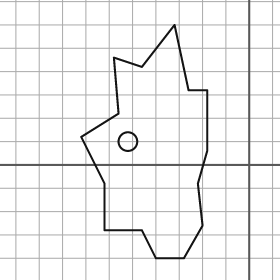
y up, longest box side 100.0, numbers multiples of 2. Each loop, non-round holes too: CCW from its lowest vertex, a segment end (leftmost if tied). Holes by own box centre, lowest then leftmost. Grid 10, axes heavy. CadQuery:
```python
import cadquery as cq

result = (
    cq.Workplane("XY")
    .moveTo(-40.0, -40.0)
    .lineTo(-28.0, -40.0)
    .lineTo(-20.0, -26.0)
    .lineTo(-22.0, -8.0)
    .lineTo(-18.0, 6.0)
    .lineTo(-18.0, 32.0)
    .lineTo(-26.0, 32.0)
    .lineTo(-32.0, 60.0)
    .lineTo(-46.0, 42.0)
    .lineTo(-58.0, 46.0)
    .lineTo(-56.0, 22.0)
    .lineTo(-72.0, 12.0)
    .lineTo(-62.0, -8.0)
    .lineTo(-62.0, -28.0)
    .lineTo(-46.0, -28.0)
    .close()
    .moveTo(-52.0, 10.0)
    .circle(4.0)
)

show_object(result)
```